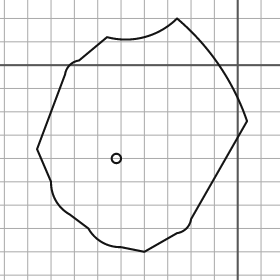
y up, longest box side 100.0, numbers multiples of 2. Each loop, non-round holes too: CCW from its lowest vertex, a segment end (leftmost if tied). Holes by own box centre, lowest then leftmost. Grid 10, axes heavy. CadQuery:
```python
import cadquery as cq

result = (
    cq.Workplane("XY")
    .moveTo(-40.0, -80.0)
    .lineTo(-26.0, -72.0)
    .threePointArc((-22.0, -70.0), (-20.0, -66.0))
    .lineTo(4.0, -24.0)
    .threePointArc((-8.0, 0.0), (-26.0, 20.0))
    .threePointArc((-40.0, 12.0), (-56.0, 12.0))
    .lineTo(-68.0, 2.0)
    .threePointArc((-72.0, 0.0), (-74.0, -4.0))
    .lineTo(-86.0, -36.0)
    .lineTo(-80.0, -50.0)
    .threePointArc((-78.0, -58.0), (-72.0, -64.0))
    .lineTo(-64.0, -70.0)
    .threePointArc((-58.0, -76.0), (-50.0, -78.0))
    .close()
    .moveTo(-52.0, -40.0)
    .circle(2.0)
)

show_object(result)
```